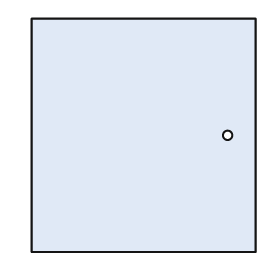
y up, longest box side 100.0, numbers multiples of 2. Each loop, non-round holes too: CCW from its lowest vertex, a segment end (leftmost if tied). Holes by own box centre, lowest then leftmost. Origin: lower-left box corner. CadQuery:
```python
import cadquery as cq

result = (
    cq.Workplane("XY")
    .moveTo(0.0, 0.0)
    .lineTo(96.0, 0.0)
    .lineTo(96.0, 100.0)
    .lineTo(0.0, 100.0)
    .close()
    .moveTo(84.0, 50.0)
    .circle(2.0)
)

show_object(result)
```